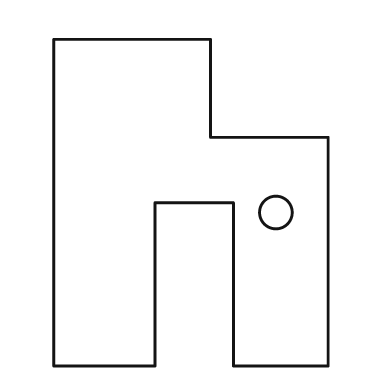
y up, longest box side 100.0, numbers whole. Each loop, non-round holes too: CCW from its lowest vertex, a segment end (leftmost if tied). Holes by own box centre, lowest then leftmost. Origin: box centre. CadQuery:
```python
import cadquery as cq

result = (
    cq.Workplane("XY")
    .moveTo(-42.0, -50.0)
    .lineTo(-11.0, -50.0)
    .lineTo(-11.0, 0.0)
    .lineTo(13.0, 0.0)
    .lineTo(13.0, -50.0)
    .lineTo(42.0, -50.0)
    .lineTo(42.0, 20.0)
    .lineTo(6.0, 20.0)
    .lineTo(6.0, 50.0)
    .lineTo(-42.0, 50.0)
    .close()
    .moveTo(26.0, -3.0)
    .circle(5.0)
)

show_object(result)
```